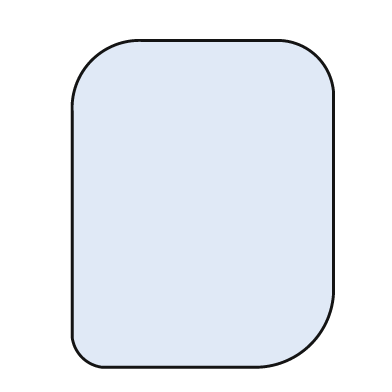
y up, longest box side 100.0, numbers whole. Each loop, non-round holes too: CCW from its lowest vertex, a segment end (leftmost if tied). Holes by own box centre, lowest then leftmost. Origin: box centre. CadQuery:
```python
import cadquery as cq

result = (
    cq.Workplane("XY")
    .moveTo(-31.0, -50.0)
    .lineTo(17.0, -50.0)
    .threePointArc((33.0, -43.0), (40.0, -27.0))
    .lineTo(40.0, 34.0)
    .threePointArc((35.0, 45.0), (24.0, 50.0))
    .lineTo(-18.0, 50.0)
    .threePointArc((-34.0, 44.0), (-40.0, 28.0))
    .lineTo(-40.0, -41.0)
    .threePointArc((-37.0, -47.0), (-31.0, -50.0))
    .close()
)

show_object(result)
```